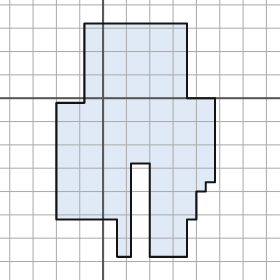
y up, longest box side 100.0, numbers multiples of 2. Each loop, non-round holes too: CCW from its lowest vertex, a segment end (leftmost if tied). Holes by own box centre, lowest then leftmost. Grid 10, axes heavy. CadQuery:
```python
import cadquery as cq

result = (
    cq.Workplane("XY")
    .moveTo(6.0, -68.0)
    .lineTo(12.0, -68.0)
    .lineTo(12.0, -28.0)
    .lineTo(20.0, -28.0)
    .lineTo(20.0, -68.0)
    .lineTo(36.0, -68.0)
    .lineTo(36.0, -52.0)
    .lineTo(40.0, -52.0)
    .lineTo(40.0, -40.0)
    .lineTo(44.0, -40.0)
    .lineTo(44.0, -36.0)
    .lineTo(48.0, -36.0)
    .lineTo(48.0, 0.0)
    .lineTo(36.0, 0.0)
    .lineTo(36.0, 32.0)
    .lineTo(-8.0, 32.0)
    .lineTo(-8.0, -2.0)
    .lineTo(-20.0, -2.0)
    .lineTo(-20.0, -52.0)
    .lineTo(6.0, -52.0)
    .close()
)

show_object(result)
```